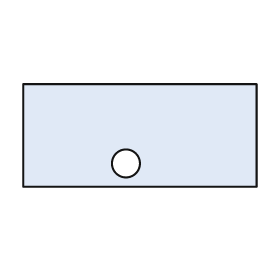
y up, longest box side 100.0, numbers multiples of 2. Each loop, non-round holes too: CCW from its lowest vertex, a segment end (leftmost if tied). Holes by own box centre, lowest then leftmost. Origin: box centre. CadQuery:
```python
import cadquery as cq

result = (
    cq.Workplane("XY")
    .moveTo(-50.0, -22.0)
    .lineTo(50.0, -22.0)
    .lineTo(50.0, 22.0)
    .lineTo(-50.0, 22.0)
    .close()
    .moveTo(-6.0, -12.0)
    .circle(6.0)
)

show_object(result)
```